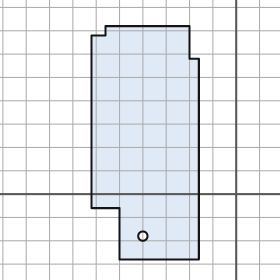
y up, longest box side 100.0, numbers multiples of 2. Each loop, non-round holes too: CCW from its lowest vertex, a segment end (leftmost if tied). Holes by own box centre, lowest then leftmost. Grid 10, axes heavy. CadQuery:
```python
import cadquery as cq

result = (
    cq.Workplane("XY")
    .moveTo(-50.0, -28.0)
    .lineTo(-16.0, -28.0)
    .lineTo(-16.0, 58.0)
    .lineTo(-20.0, 58.0)
    .lineTo(-20.0, 72.0)
    .lineTo(-56.0, 72.0)
    .lineTo(-56.0, 68.0)
    .lineTo(-62.0, 68.0)
    .lineTo(-62.0, -6.0)
    .lineTo(-50.0, -6.0)
    .close()
    .moveTo(-40.0, -18.0)
    .circle(2.0)
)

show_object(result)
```